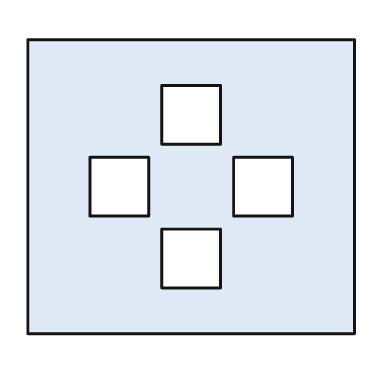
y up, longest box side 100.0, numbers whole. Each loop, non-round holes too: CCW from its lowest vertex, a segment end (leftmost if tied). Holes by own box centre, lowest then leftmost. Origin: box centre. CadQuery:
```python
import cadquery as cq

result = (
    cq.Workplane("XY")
    .moveTo(-50.0, -45.0)
    .lineTo(50.0, -45.0)
    .lineTo(50.0, 45.0)
    .lineTo(-50.0, 45.0)
    .close()
    .moveTo(-9.0, -31.0)
    .lineTo(9.0, -31.0)
    .lineTo(9.0, -13.0)
    .lineTo(-9.0, -13.0)
    .close()
    .moveTo(-31.0, -9.0)
    .lineTo(-13.0, -9.0)
    .lineTo(-13.0, 9.0)
    .lineTo(-31.0, 9.0)
    .close()
    .moveTo(13.0, -9.0)
    .lineTo(31.0, -9.0)
    .lineTo(31.0, 9.0)
    .lineTo(13.0, 9.0)
    .close()
    .moveTo(-9.0, 13.0)
    .lineTo(9.0, 13.0)
    .lineTo(9.0, 31.0)
    .lineTo(-9.0, 31.0)
    .close()
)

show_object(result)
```